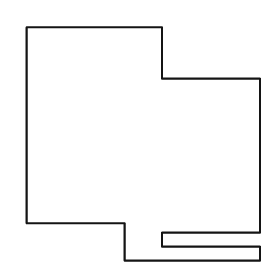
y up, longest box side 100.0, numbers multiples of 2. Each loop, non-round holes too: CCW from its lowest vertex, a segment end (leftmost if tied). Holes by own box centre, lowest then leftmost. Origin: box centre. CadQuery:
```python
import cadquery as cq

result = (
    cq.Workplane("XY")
    .moveTo(-8.0, -50.0)
    .lineTo(50.0, -50.0)
    .lineTo(50.0, -44.0)
    .lineTo(8.0, -44.0)
    .lineTo(8.0, -38.0)
    .lineTo(50.0, -38.0)
    .lineTo(50.0, 28.0)
    .lineTo(8.0, 28.0)
    .lineTo(8.0, 50.0)
    .lineTo(-50.0, 50.0)
    .lineTo(-50.0, -34.0)
    .lineTo(-8.0, -34.0)
    .close()
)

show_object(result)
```